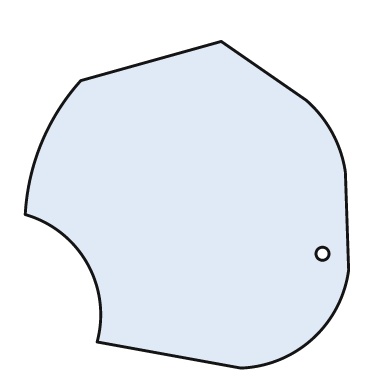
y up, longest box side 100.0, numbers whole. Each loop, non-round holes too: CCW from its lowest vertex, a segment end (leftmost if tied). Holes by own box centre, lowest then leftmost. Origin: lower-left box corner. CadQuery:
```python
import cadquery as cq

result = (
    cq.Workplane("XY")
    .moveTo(66.0, 0.0)
    .threePointArc((88.0, 9.0), (99.0, 30.0))
    .lineTo(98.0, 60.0)
    .threePointArc((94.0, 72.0), (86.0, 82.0))
    .lineTo(60.0, 100.0)
    .lineTo(17.0, 88.0)
    .threePointArc((5.0, 69.0), (0.0, 47.0))
    .threePointArc((19.0, 32.0), (22.0, 8.0))
    .close()
    .moveTo(91.0, 35.0)
    .circle(2.0)
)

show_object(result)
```